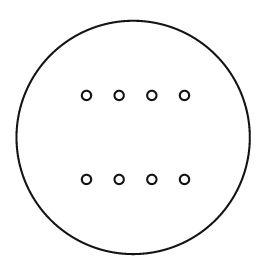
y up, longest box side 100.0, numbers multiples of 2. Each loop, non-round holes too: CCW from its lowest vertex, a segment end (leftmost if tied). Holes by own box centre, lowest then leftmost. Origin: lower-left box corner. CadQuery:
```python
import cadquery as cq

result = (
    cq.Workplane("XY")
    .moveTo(50.0, 50.0)
    .circle(50.0)
    .moveTo(30.0, 32.0)
    .circle(2.0)
    .moveTo(44.0, 32.0)
    .circle(2.0)
    .moveTo(58.0, 32.0)
    .circle(2.0)
    .moveTo(72.0, 32.0)
    .circle(2.0)
    .moveTo(30.0, 68.0)
    .circle(2.0)
    .moveTo(44.0, 68.0)
    .circle(2.0)
    .moveTo(58.0, 68.0)
    .circle(2.0)
    .moveTo(72.0, 68.0)
    .circle(2.0)
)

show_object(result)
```